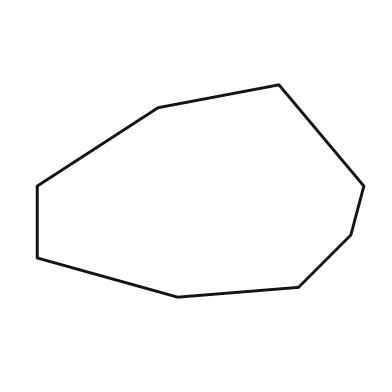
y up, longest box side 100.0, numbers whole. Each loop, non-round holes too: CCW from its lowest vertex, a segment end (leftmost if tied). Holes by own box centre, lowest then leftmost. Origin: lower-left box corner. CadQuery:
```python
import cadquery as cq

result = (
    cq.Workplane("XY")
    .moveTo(43.0, 0.0)
    .lineTo(80.0, 3.0)
    .lineTo(96.0, 19.0)
    .lineTo(100.0, 34.0)
    .lineTo(74.0, 65.0)
    .lineTo(37.0, 58.0)
    .lineTo(0.0, 34.0)
    .lineTo(0.0, 12.0)
    .close()
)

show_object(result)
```